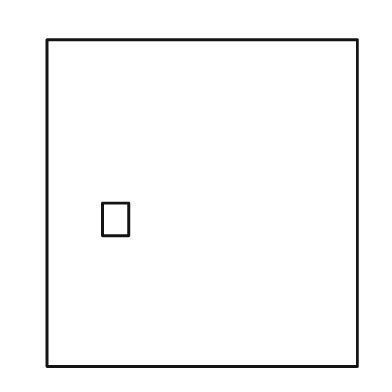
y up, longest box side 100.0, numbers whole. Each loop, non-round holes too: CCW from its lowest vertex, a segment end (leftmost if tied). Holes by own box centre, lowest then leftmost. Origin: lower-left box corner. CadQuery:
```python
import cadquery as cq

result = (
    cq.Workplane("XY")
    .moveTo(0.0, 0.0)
    .lineTo(95.0, 0.0)
    .lineTo(95.0, 100.0)
    .lineTo(0.0, 100.0)
    .close()
    .moveTo(17.0, 40.0)
    .lineTo(25.0, 40.0)
    .lineTo(25.0, 50.0)
    .lineTo(17.0, 50.0)
    .close()
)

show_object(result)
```